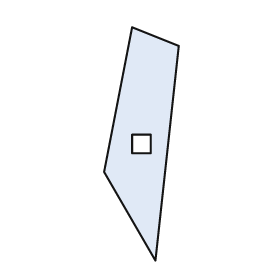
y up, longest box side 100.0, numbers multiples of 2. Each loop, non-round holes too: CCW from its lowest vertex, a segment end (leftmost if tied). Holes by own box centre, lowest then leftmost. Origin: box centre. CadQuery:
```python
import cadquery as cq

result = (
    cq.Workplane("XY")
    .moveTo(6.0, -50.0)
    .lineTo(16.0, 42.0)
    .lineTo(-4.0, 50.0)
    .lineTo(-16.0, -12.0)
    .close()
    .moveTo(-4.0, -4.0)
    .lineTo(4.0, -4.0)
    .lineTo(4.0, 4.0)
    .lineTo(-4.0, 4.0)
    .close()
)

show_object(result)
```